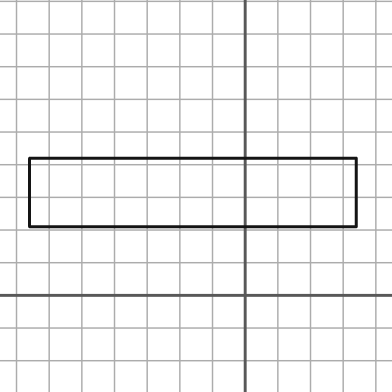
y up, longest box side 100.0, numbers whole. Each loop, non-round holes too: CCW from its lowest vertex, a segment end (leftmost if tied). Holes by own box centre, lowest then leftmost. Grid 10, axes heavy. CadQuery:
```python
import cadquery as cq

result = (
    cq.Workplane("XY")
    .moveTo(-66.0, 21.0)
    .lineTo(34.0, 21.0)
    .lineTo(34.0, 42.0)
    .lineTo(-66.0, 42.0)
    .close()
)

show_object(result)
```